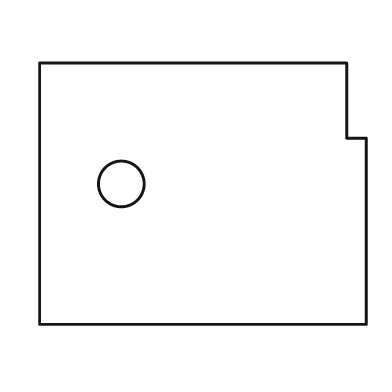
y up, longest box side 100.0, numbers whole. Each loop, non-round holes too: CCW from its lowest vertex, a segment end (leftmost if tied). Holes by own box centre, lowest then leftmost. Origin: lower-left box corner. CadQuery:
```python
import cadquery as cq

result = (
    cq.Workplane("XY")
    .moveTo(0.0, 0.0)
    .lineTo(100.0, 0.0)
    .lineTo(100.0, 57.0)
    .lineTo(94.0, 57.0)
    .lineTo(94.0, 80.0)
    .lineTo(0.0, 80.0)
    .close()
    .moveTo(25.0, 43.0)
    .circle(7.0)
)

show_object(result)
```